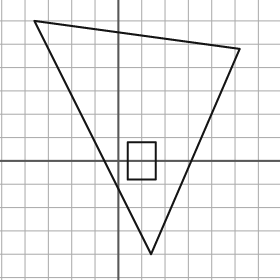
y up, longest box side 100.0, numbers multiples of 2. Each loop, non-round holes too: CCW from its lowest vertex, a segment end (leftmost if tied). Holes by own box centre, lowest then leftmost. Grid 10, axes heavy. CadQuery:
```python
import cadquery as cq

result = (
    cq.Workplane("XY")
    .moveTo(14.0, -40.0)
    .lineTo(52.0, 48.0)
    .lineTo(-36.0, 60.0)
    .close()
    .moveTo(4.0, -8.0)
    .lineTo(16.0, -8.0)
    .lineTo(16.0, 8.0)
    .lineTo(4.0, 8.0)
    .close()
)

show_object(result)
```